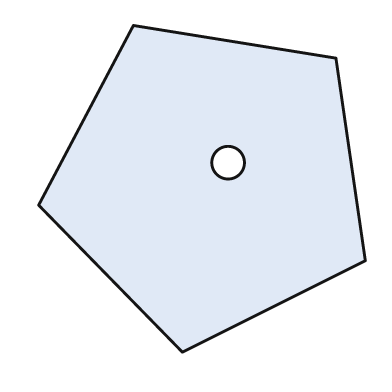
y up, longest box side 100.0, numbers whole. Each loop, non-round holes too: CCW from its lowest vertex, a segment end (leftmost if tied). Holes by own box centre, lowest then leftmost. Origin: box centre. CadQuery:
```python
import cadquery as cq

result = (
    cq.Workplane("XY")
    .moveTo(-6.0, -50.0)
    .lineTo(50.0, -22.0)
    .lineTo(41.0, 40.0)
    .lineTo(-21.0, 50.0)
    .lineTo(-50.0, -5.0)
    .close()
    .moveTo(8.0, 8.0)
    .circle(5.0)
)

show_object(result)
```